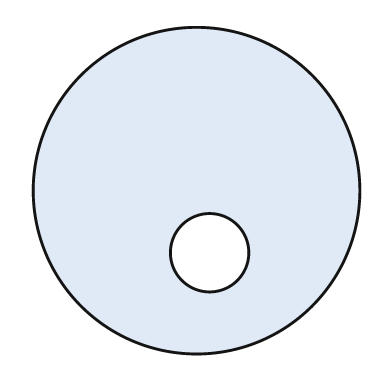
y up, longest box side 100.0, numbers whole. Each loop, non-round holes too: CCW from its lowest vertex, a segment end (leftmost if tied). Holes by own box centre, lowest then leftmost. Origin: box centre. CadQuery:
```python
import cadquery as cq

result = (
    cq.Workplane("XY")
    .moveTo(0.0, 0.0)
    .circle(50.0)
    .moveTo(4.0, -19.0)
    .circle(12.0)
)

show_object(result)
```